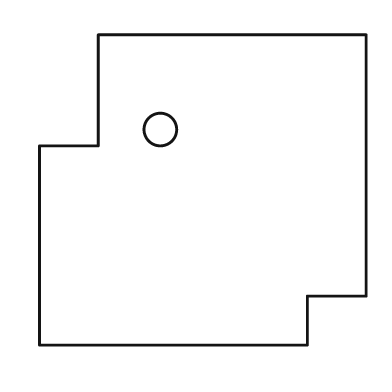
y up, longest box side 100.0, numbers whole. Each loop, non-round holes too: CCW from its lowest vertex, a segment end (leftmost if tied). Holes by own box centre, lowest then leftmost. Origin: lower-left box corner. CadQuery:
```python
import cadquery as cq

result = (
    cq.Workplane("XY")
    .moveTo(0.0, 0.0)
    .lineTo(82.0, 0.0)
    .lineTo(82.0, 15.0)
    .lineTo(100.0, 15.0)
    .lineTo(100.0, 95.0)
    .lineTo(18.0, 95.0)
    .lineTo(18.0, 61.0)
    .lineTo(0.0, 61.0)
    .close()
    .moveTo(37.0, 66.0)
    .circle(5.0)
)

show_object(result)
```